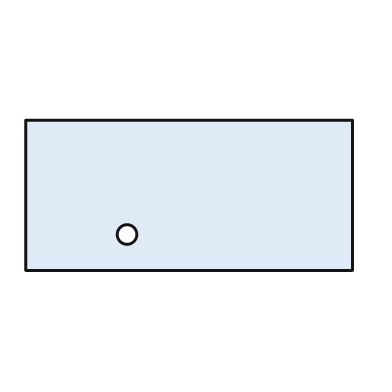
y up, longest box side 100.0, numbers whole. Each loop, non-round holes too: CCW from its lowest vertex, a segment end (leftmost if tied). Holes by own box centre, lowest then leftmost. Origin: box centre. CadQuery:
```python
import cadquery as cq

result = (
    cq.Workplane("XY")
    .moveTo(-50.0, -23.0)
    .lineTo(50.0, -23.0)
    .lineTo(50.0, 23.0)
    .lineTo(-50.0, 23.0)
    .close()
    .moveTo(-19.0, -12.0)
    .circle(3.0)
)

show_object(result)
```